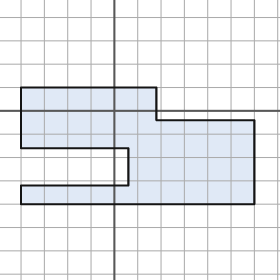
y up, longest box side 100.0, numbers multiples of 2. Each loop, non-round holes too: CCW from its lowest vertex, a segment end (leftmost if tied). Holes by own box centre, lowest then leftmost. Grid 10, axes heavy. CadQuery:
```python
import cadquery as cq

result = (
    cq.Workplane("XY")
    .moveTo(-40.0, -40.0)
    .lineTo(60.0, -40.0)
    .lineTo(60.0, -4.0)
    .lineTo(18.0, -4.0)
    .lineTo(18.0, 10.0)
    .lineTo(-40.0, 10.0)
    .lineTo(-40.0, -16.0)
    .lineTo(6.0, -16.0)
    .lineTo(6.0, -32.0)
    .lineTo(-40.0, -32.0)
    .close()
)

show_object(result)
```